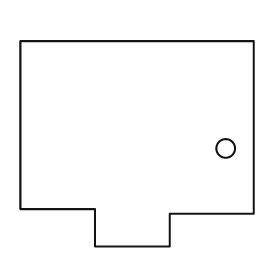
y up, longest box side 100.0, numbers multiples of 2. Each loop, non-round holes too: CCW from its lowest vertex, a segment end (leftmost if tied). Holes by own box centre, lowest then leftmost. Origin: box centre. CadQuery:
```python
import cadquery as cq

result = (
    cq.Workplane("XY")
    .moveTo(-18.0, -44.0)
    .lineTo(14.0, -44.0)
    .lineTo(14.0, -30.0)
    .lineTo(50.0, -30.0)
    .lineTo(50.0, 44.0)
    .lineTo(-50.0, 44.0)
    .lineTo(-50.0, -28.0)
    .lineTo(-18.0, -28.0)
    .close()
    .moveTo(38.0, -2.0)
    .circle(4.0)
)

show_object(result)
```